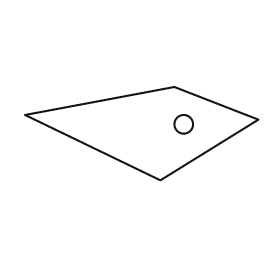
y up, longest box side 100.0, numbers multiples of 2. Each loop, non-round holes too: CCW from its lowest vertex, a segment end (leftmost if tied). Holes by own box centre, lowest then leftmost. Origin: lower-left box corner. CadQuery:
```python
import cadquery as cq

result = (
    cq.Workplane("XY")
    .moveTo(58.0, 0.0)
    .lineTo(100.0, 26.0)
    .lineTo(64.0, 40.0)
    .lineTo(0.0, 28.0)
    .close()
    .moveTo(68.0, 24.0)
    .circle(4.0)
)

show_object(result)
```